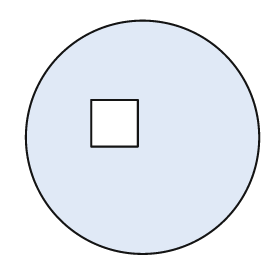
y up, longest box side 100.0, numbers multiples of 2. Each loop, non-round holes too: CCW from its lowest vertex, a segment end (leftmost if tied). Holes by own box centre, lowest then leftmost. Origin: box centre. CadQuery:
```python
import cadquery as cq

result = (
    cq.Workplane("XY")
    .moveTo(0.0, 0.0)
    .circle(50.0)
    .moveTo(-22.0, -4.0)
    .lineTo(-2.0, -4.0)
    .lineTo(-2.0, 16.0)
    .lineTo(-22.0, 16.0)
    .close()
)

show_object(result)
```